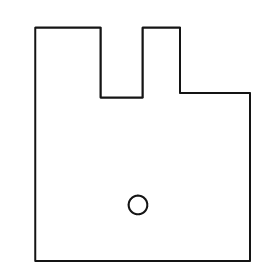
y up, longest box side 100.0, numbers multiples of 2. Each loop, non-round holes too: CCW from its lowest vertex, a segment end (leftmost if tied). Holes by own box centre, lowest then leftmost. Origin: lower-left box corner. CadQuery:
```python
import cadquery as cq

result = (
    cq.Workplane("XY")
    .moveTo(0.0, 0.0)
    .lineTo(92.0, 0.0)
    .lineTo(92.0, 72.0)
    .lineTo(62.0, 72.0)
    .lineTo(62.0, 100.0)
    .lineTo(46.0, 100.0)
    .lineTo(46.0, 70.0)
    .lineTo(28.0, 70.0)
    .lineTo(28.0, 100.0)
    .lineTo(0.0, 100.0)
    .close()
    .moveTo(44.0, 24.0)
    .circle(4.0)
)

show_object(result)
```